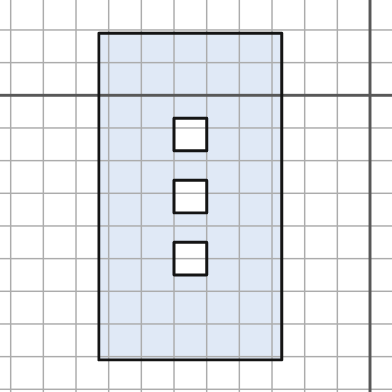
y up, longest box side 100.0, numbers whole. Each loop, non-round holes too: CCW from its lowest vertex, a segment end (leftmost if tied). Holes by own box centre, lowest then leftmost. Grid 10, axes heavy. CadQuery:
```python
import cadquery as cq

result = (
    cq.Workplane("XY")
    .moveTo(-83.0, -81.0)
    .lineTo(-27.0, -81.0)
    .lineTo(-27.0, 19.0)
    .lineTo(-83.0, 19.0)
    .close()
    .moveTo(-60.0, -55.0)
    .lineTo(-50.0, -55.0)
    .lineTo(-50.0, -45.0)
    .lineTo(-60.0, -45.0)
    .close()
    .moveTo(-60.0, -36.0)
    .lineTo(-50.0, -36.0)
    .lineTo(-50.0, -26.0)
    .lineTo(-60.0, -26.0)
    .close()
    .moveTo(-60.0, -17.0)
    .lineTo(-50.0, -17.0)
    .lineTo(-50.0, -7.0)
    .lineTo(-60.0, -7.0)
    .close()
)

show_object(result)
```